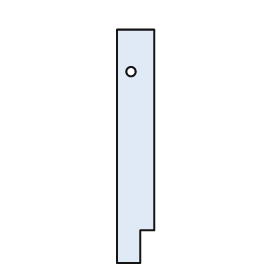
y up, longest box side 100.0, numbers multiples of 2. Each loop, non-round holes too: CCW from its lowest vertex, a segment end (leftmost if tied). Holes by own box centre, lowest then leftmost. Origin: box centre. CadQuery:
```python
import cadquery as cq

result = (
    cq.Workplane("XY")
    .moveTo(-8.0, -50.0)
    .lineTo(2.0, -50.0)
    .lineTo(2.0, -36.0)
    .lineTo(8.0, -36.0)
    .lineTo(8.0, 50.0)
    .lineTo(-8.0, 50.0)
    .close()
    .moveTo(-2.0, 32.0)
    .circle(2.0)
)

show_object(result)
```